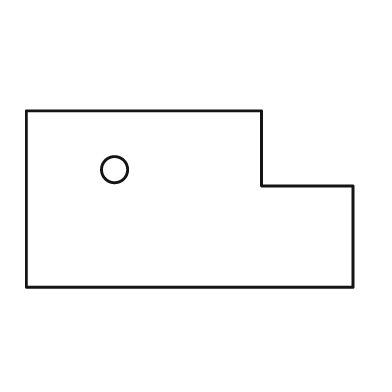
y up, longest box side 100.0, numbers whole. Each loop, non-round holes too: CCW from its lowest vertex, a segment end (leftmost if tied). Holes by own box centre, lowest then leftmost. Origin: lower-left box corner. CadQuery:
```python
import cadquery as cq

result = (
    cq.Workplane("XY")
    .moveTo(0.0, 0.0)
    .lineTo(100.0, 0.0)
    .lineTo(100.0, 31.0)
    .lineTo(72.0, 31.0)
    .lineTo(72.0, 54.0)
    .lineTo(0.0, 54.0)
    .close()
    .moveTo(27.0, 36.0)
    .circle(4.0)
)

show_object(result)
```